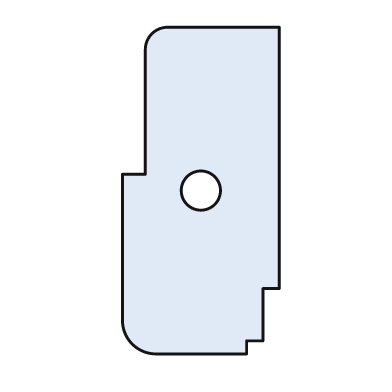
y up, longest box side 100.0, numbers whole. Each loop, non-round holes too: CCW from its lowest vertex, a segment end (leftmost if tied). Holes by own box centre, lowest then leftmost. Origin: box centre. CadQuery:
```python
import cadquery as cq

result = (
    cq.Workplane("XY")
    .moveTo(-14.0, -50.0)
    .lineTo(14.0, -50.0)
    .lineTo(14.0, -46.0)
    .lineTo(19.0, -46.0)
    .lineTo(19.0, -30.0)
    .lineTo(24.0, -30.0)
    .lineTo(24.0, 50.0)
    .lineTo(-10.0, 50.0)
    .threePointArc((-15.0, 48.0), (-17.0, 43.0))
    .lineTo(-17.0, 5.0)
    .lineTo(-24.0, 5.0)
    .lineTo(-24.0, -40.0)
    .threePointArc((-21.0, -47.0), (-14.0, -50.0))
    .close()
    .moveTo(0.0, 0.0)
    .circle(6.0)
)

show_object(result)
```